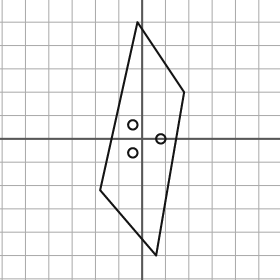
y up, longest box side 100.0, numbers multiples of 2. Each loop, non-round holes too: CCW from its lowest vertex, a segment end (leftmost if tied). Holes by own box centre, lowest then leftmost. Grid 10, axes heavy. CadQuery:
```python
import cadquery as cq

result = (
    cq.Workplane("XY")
    .moveTo(6.0, -50.0)
    .lineTo(18.0, 20.0)
    .lineTo(-2.0, 50.0)
    .lineTo(-18.0, -22.0)
    .close()
    .moveTo(-4.0, -6.0)
    .circle(2.0)
    .moveTo(8.0, 0.0)
    .circle(2.0)
    .moveTo(-4.0, 6.0)
    .circle(2.0)
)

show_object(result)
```